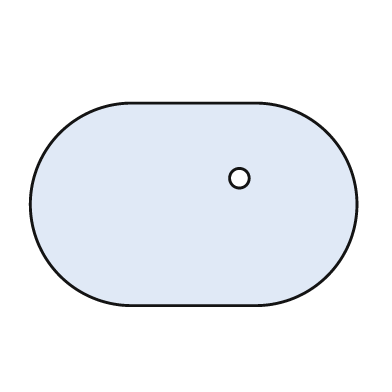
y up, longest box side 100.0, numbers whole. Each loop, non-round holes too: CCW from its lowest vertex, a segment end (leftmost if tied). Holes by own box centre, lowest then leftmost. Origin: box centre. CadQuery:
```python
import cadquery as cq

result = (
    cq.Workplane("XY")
    .moveTo(-19.0, -31.0)
    .lineTo(19.0, -31.0)
    .threePointArc((50.0, 0.0), (19.0, 31.0))
    .lineTo(-19.0, 31.0)
    .threePointArc((-50.0, 0.0), (-19.0, -31.0))
    .close()
    .moveTo(14.0, 8.0)
    .circle(3.0)
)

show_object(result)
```